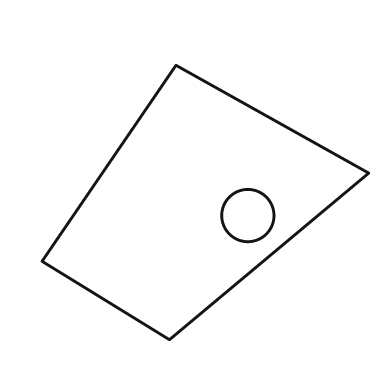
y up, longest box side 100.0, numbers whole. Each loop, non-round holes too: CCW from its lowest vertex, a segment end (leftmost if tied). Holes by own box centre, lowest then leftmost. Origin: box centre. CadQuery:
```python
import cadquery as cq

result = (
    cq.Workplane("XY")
    .moveTo(-11.0, -42.0)
    .lineTo(50.0, 9.0)
    .lineTo(-9.0, 42.0)
    .lineTo(-50.0, -18.0)
    .close()
    .moveTo(13.0, -4.0)
    .circle(8.0)
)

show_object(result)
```